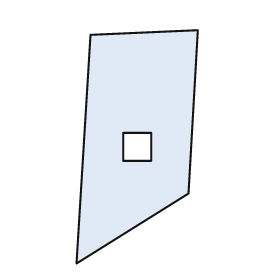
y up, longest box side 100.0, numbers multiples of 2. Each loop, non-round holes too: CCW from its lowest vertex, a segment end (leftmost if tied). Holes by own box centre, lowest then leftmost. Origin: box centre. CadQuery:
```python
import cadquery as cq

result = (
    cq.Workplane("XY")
    .moveTo(-26.0, -50.0)
    .lineTo(22.0, -20.0)
    .lineTo(26.0, 50.0)
    .lineTo(-20.0, 48.0)
    .close()
    .moveTo(-6.0, -6.0)
    .lineTo(6.0, -6.0)
    .lineTo(6.0, 6.0)
    .lineTo(-6.0, 6.0)
    .close()
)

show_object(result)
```